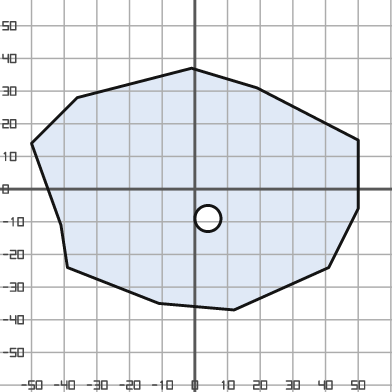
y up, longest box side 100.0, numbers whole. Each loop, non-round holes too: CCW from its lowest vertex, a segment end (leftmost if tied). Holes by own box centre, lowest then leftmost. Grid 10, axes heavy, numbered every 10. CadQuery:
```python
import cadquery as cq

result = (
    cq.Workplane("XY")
    .moveTo(12.0, -37.0)
    .lineTo(41.0, -24.0)
    .lineTo(50.0, -6.0)
    .lineTo(50.0, 15.0)
    .lineTo(19.0, 31.0)
    .lineTo(-1.0, 37.0)
    .lineTo(-36.0, 28.0)
    .lineTo(-50.0, 14.0)
    .lineTo(-41.0, -11.0)
    .lineTo(-39.0, -24.0)
    .lineTo(-11.0, -35.0)
    .close()
    .moveTo(4.0, -9.0)
    .circle(4.0)
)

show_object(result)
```